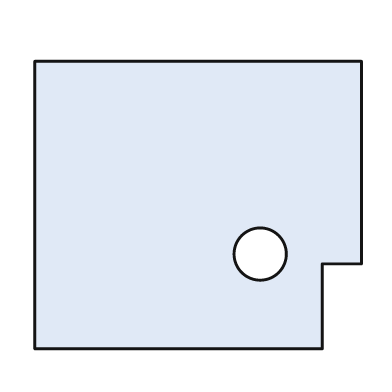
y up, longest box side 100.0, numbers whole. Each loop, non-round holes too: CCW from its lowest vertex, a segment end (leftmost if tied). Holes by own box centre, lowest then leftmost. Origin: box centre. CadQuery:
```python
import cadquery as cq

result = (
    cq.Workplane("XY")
    .moveTo(-50.0, -44.0)
    .lineTo(38.0, -44.0)
    .lineTo(38.0, -18.0)
    .lineTo(50.0, -18.0)
    .lineTo(50.0, 44.0)
    .lineTo(-50.0, 44.0)
    .close()
    .moveTo(19.0, -15.0)
    .circle(8.0)
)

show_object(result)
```